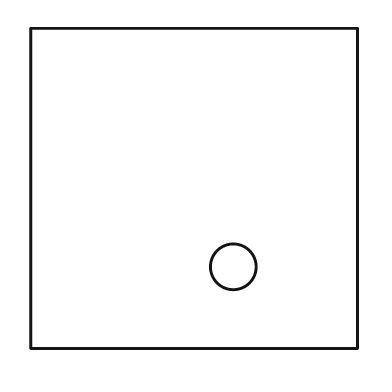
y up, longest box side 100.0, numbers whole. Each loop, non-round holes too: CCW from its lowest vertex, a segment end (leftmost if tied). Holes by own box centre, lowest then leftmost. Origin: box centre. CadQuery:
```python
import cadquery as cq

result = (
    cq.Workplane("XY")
    .moveTo(-50.0, -49.0)
    .lineTo(50.0, -49.0)
    .lineTo(50.0, 49.0)
    .lineTo(-50.0, 49.0)
    .close()
    .moveTo(12.0, -24.0)
    .circle(7.0)
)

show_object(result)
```